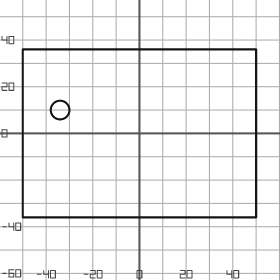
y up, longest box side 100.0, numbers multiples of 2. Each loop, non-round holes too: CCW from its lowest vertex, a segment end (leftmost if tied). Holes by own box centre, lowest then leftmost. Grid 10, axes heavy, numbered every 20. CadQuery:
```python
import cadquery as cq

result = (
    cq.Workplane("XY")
    .moveTo(-50.0, -36.0)
    .lineTo(50.0, -36.0)
    .lineTo(50.0, 36.0)
    .lineTo(-50.0, 36.0)
    .close()
    .moveTo(-34.0, 10.0)
    .circle(4.0)
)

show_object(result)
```